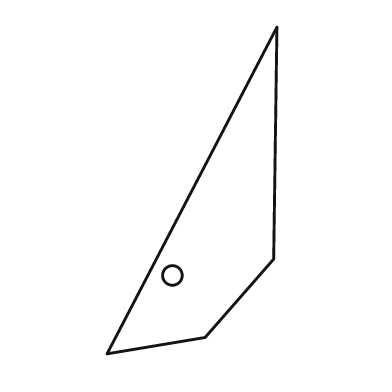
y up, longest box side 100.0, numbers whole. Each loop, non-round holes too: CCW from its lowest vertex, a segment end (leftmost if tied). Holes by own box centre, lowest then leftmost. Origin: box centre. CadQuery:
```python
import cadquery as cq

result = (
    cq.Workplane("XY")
    .moveTo(-26.0, -50.0)
    .lineTo(4.0, -45.0)
    .lineTo(25.0, -21.0)
    .lineTo(26.0, 50.0)
    .close()
    .moveTo(-6.0, -26.0)
    .circle(3.0)
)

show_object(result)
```